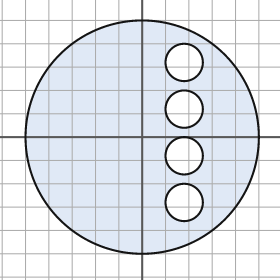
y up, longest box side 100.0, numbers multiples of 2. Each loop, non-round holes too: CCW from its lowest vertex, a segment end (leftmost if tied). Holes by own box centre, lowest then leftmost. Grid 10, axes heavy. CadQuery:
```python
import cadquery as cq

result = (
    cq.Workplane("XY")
    .moveTo(0.0, 0.0)
    .circle(50.0)
    .moveTo(18.0, -28.0)
    .circle(8.0)
    .moveTo(18.0, -8.0)
    .circle(8.0)
    .moveTo(18.0, 12.0)
    .circle(8.0)
    .moveTo(18.0, 32.0)
    .circle(8.0)
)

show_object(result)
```